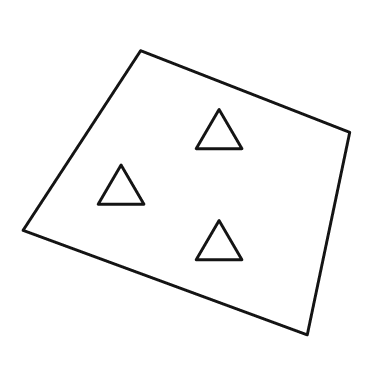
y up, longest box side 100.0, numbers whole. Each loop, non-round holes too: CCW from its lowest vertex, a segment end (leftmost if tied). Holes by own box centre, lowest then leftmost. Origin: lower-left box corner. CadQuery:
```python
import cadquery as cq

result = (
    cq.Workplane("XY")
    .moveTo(87.0, 0.0)
    .lineTo(100.0, 62.0)
    .lineTo(36.0, 87.0)
    .lineTo(0.0, 32.0)
    .close()
    .moveTo(53.0, 23.0)
    .lineTo(67.0, 23.0)
    .lineTo(60.0, 35.0)
    .close()
    .moveTo(23.0, 40.0)
    .lineTo(37.0, 40.0)
    .lineTo(30.0, 52.0)
    .close()
    .moveTo(53.0, 57.0)
    .lineTo(67.0, 57.0)
    .lineTo(60.0, 69.0)
    .close()
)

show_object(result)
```